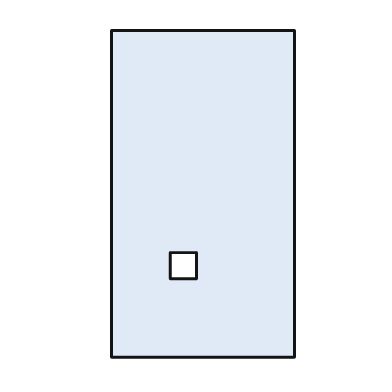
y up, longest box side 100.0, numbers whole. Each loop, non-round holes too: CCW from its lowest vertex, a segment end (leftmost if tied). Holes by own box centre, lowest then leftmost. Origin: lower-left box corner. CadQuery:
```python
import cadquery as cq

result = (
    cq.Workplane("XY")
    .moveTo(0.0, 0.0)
    .lineTo(56.0, 0.0)
    .lineTo(56.0, 100.0)
    .lineTo(0.0, 100.0)
    .close()
    .moveTo(18.0, 24.0)
    .lineTo(26.0, 24.0)
    .lineTo(26.0, 32.0)
    .lineTo(18.0, 32.0)
    .close()
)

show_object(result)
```